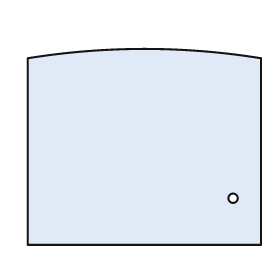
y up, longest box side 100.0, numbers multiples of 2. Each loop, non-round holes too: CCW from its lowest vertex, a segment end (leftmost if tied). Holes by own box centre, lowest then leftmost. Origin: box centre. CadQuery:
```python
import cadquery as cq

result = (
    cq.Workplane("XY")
    .moveTo(-50.0, -42.0)
    .lineTo(50.0, -42.0)
    .lineTo(50.0, 38.0)
    .threePointArc((0.0, 42.0), (-50.0, 38.0))
    .close()
    .moveTo(38.0, -22.0)
    .circle(2.0)
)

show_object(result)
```